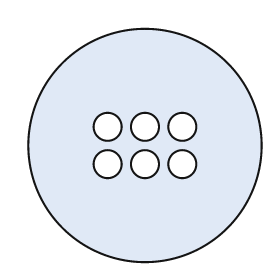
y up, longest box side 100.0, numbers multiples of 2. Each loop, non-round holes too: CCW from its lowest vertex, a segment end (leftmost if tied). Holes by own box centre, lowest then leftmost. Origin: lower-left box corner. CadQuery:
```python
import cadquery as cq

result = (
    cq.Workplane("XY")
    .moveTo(50.0, 50.0)
    .circle(50.0)
    .moveTo(34.0, 42.0)
    .circle(6.0)
    .moveTo(50.0, 42.0)
    .circle(6.0)
    .moveTo(66.0, 42.0)
    .circle(6.0)
    .moveTo(34.0, 58.0)
    .circle(6.0)
    .moveTo(50.0, 58.0)
    .circle(6.0)
    .moveTo(66.0, 58.0)
    .circle(6.0)
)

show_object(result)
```